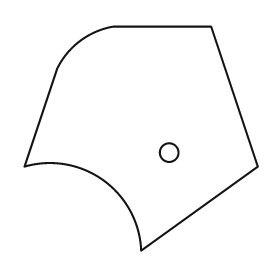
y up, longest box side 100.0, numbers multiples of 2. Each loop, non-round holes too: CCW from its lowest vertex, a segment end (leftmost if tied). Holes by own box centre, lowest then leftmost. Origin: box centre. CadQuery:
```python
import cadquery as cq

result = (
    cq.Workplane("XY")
    .moveTo(0.0, -48.0)
    .lineTo(50.0, -12.0)
    .lineTo(30.0, 48.0)
    .lineTo(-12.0, 48.0)
    .threePointArc((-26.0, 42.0), (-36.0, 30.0))
    .lineTo(-50.0, -12.0)
    .threePointArc((-16.0, -18.0), (0.0, -48.0))
    .close()
    .moveTo(12.0, -6.0)
    .circle(4.0)
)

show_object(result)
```